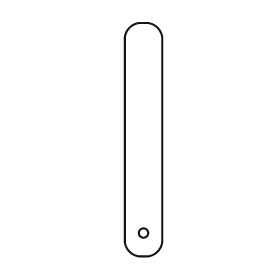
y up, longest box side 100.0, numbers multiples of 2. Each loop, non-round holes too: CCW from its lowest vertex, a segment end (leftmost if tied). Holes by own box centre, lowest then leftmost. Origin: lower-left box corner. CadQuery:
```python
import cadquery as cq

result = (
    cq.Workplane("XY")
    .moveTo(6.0, 0.0)
    .lineTo(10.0, 0.0)
    .threePointArc((14.0, 2.0), (16.0, 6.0))
    .lineTo(16.0, 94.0)
    .threePointArc((14.0, 98.0), (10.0, 100.0))
    .lineTo(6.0, 100.0)
    .threePointArc((2.0, 98.0), (0.0, 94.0))
    .lineTo(0.0, 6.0)
    .threePointArc((2.0, 2.0), (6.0, 0.0))
    .close()
    .moveTo(8.0, 10.0)
    .circle(2.0)
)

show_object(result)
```